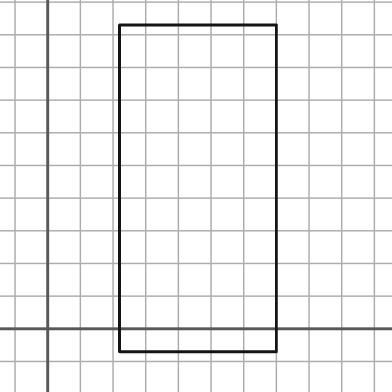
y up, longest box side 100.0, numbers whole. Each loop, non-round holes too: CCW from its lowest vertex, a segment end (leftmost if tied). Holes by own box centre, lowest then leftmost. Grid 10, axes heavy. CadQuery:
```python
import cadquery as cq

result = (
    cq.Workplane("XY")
    .moveTo(22.0, -7.0)
    .lineTo(70.0, -7.0)
    .lineTo(70.0, 93.0)
    .lineTo(22.0, 93.0)
    .close()
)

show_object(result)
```